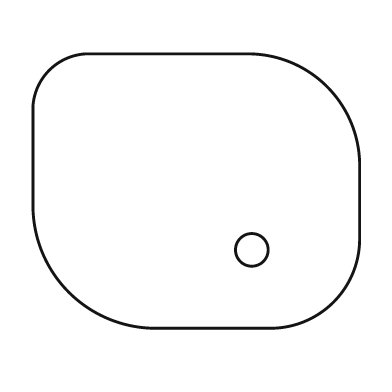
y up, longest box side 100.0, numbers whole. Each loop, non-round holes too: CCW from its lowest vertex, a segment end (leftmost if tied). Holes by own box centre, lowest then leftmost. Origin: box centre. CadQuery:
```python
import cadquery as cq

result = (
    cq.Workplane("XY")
    .moveTo(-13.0, -42.0)
    .lineTo(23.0, -42.0)
    .threePointArc((42.0, -34.0), (50.0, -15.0))
    .lineTo(50.0, 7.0)
    .threePointArc((40.0, 32.0), (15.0, 42.0))
    .lineTo(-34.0, 42.0)
    .threePointArc((-45.0, 37.0), (-50.0, 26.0))
    .lineTo(-50.0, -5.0)
    .threePointArc((-39.0, -31.0), (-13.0, -42.0))
    .close()
    .moveTo(17.0, -18.0)
    .circle(5.0)
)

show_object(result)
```